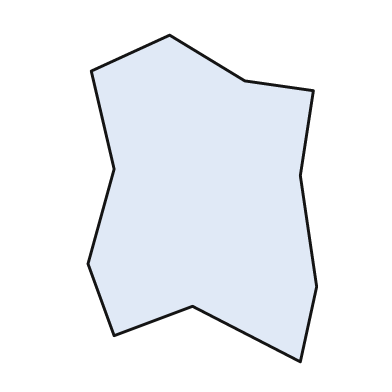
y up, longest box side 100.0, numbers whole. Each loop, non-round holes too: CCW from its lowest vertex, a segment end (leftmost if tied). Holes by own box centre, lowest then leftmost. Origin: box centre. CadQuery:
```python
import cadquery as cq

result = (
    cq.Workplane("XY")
    .moveTo(30.0, -50.0)
    .lineTo(35.0, -27.0)
    .lineTo(30.0, 7.0)
    .lineTo(34.0, 33.0)
    .lineTo(13.0, 36.0)
    .lineTo(-10.0, 50.0)
    .lineTo(-34.0, 39.0)
    .lineTo(-27.0, 9.0)
    .lineTo(-35.0, -20.0)
    .lineTo(-27.0, -42.0)
    .lineTo(-3.0, -33.0)
    .close()
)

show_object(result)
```